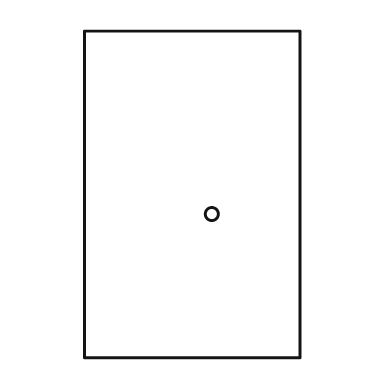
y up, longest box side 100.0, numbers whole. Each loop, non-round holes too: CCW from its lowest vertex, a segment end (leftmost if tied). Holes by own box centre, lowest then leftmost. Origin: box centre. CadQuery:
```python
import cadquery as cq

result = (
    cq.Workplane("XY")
    .moveTo(-33.0, -50.0)
    .lineTo(33.0, -50.0)
    .lineTo(33.0, 50.0)
    .lineTo(-33.0, 50.0)
    .close()
    .moveTo(6.0, -6.0)
    .circle(2.0)
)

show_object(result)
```